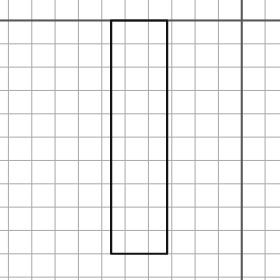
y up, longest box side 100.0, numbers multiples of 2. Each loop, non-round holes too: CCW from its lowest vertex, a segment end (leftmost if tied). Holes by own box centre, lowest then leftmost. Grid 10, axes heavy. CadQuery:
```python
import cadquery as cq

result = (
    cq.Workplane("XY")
    .moveTo(-56.0, -100.0)
    .lineTo(-32.0, -100.0)
    .lineTo(-32.0, 0.0)
    .lineTo(-56.0, 0.0)
    .close()
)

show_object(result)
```